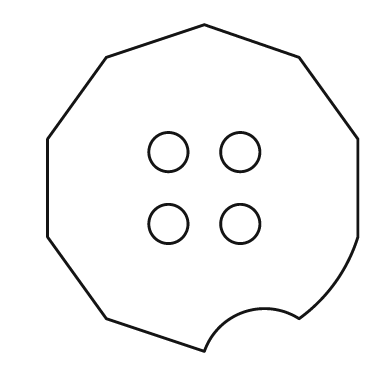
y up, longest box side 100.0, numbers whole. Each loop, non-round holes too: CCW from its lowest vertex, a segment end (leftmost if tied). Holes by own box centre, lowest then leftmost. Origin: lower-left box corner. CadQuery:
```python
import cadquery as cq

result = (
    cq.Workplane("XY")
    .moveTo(48.0, 0.0)
    .threePointArc((60.0, 12.0), (77.0, 10.0))
    .threePointArc((88.0, 21.0), (95.0, 35.0))
    .lineTo(95.0, 65.0)
    .lineTo(77.0, 90.0)
    .lineTo(48.0, 100.0)
    .lineTo(18.0, 90.0)
    .lineTo(0.0, 65.0)
    .lineTo(0.0, 35.0)
    .lineTo(18.0, 10.0)
    .close()
    .moveTo(37.0, 39.0)
    .circle(6.0)
    .moveTo(59.0, 39.0)
    .circle(6.0)
    .moveTo(37.0, 61.0)
    .circle(6.0)
    .moveTo(59.0, 61.0)
    .circle(6.0)
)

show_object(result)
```